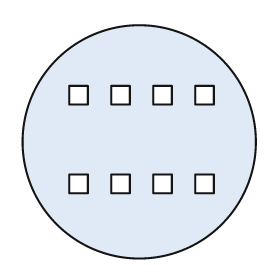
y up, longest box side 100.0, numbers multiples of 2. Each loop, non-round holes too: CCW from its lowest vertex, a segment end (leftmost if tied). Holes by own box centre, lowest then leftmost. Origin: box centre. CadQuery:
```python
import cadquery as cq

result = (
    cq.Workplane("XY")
    .moveTo(0.0, 0.0)
    .circle(50.0)
    .moveTo(-30.0, -22.0)
    .lineTo(-22.0, -22.0)
    .lineTo(-22.0, -14.0)
    .lineTo(-30.0, -14.0)
    .close()
    .moveTo(-12.0, -22.0)
    .lineTo(-4.0, -22.0)
    .lineTo(-4.0, -14.0)
    .lineTo(-12.0, -14.0)
    .close()
    .moveTo(6.0, -22.0)
    .lineTo(14.0, -22.0)
    .lineTo(14.0, -14.0)
    .lineTo(6.0, -14.0)
    .close()
    .moveTo(24.0, -22.0)
    .lineTo(32.0, -22.0)
    .lineTo(32.0, -14.0)
    .lineTo(24.0, -14.0)
    .close()
    .moveTo(-30.0, 16.0)
    .lineTo(-22.0, 16.0)
    .lineTo(-22.0, 24.0)
    .lineTo(-30.0, 24.0)
    .close()
    .moveTo(-12.0, 16.0)
    .lineTo(-4.0, 16.0)
    .lineTo(-4.0, 24.0)
    .lineTo(-12.0, 24.0)
    .close()
    .moveTo(6.0, 16.0)
    .lineTo(14.0, 16.0)
    .lineTo(14.0, 24.0)
    .lineTo(6.0, 24.0)
    .close()
    .moveTo(24.0, 16.0)
    .lineTo(32.0, 16.0)
    .lineTo(32.0, 24.0)
    .lineTo(24.0, 24.0)
    .close()
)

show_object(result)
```